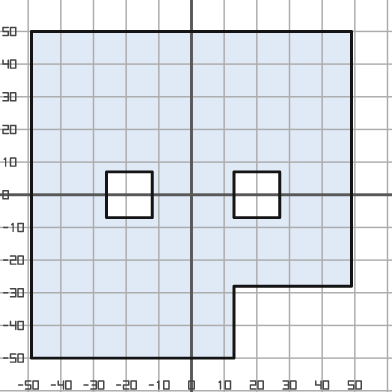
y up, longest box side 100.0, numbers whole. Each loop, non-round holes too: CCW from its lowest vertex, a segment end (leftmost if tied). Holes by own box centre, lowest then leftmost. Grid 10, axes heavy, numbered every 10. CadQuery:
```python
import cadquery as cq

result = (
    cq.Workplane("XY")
    .moveTo(-49.0, -50.0)
    .lineTo(13.0, -50.0)
    .lineTo(13.0, -28.0)
    .lineTo(49.0, -28.0)
    .lineTo(49.0, 50.0)
    .lineTo(-49.0, 50.0)
    .close()
    .moveTo(-26.0, -7.0)
    .lineTo(-12.0, -7.0)
    .lineTo(-12.0, 7.0)
    .lineTo(-26.0, 7.0)
    .close()
    .moveTo(13.0, -7.0)
    .lineTo(27.0, -7.0)
    .lineTo(27.0, 7.0)
    .lineTo(13.0, 7.0)
    .close()
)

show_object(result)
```